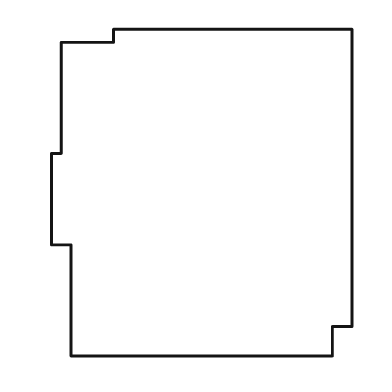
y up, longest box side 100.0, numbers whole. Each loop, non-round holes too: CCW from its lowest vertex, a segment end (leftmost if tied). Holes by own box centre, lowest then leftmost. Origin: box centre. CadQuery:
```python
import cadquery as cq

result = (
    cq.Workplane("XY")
    .moveTo(-40.0, -50.0)
    .lineTo(40.0, -50.0)
    .lineTo(40.0, -41.0)
    .lineTo(46.0, -41.0)
    .lineTo(46.0, 50.0)
    .lineTo(-27.0, 50.0)
    .lineTo(-27.0, 46.0)
    .lineTo(-43.0, 46.0)
    .lineTo(-43.0, 12.0)
    .lineTo(-46.0, 12.0)
    .lineTo(-46.0, -16.0)
    .lineTo(-40.0, -16.0)
    .close()
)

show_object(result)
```